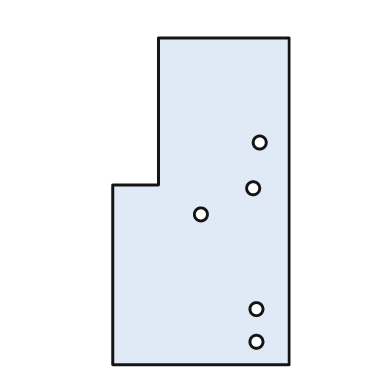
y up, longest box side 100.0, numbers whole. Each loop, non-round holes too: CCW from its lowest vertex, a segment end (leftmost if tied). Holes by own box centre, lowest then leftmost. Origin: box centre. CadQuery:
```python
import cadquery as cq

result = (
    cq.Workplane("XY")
    .moveTo(-27.0, -50.0)
    .lineTo(27.0, -50.0)
    .lineTo(27.0, 50.0)
    .lineTo(-13.0, 50.0)
    .lineTo(-13.0, 5.0)
    .lineTo(-27.0, 5.0)
    .close()
    .moveTo(17.0, -43.0)
    .circle(2.0)
    .moveTo(17.0, -33.0)
    .circle(2.0)
    .moveTo(0.0, -4.0)
    .circle(2.0)
    .moveTo(16.0, 4.0)
    .circle(2.0)
    .moveTo(18.0, 18.0)
    .circle(2.0)
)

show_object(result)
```